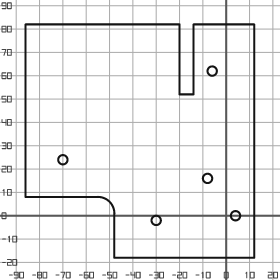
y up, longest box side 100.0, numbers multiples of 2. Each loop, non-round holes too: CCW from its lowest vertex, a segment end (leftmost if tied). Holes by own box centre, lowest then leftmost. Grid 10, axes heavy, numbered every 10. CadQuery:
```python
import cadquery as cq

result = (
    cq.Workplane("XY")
    .moveTo(-48.0, -18.0)
    .lineTo(12.0, -18.0)
    .lineTo(12.0, 82.0)
    .lineTo(-14.0, 82.0)
    .lineTo(-14.0, 52.0)
    .lineTo(-20.0, 52.0)
    .lineTo(-20.0, 82.0)
    .lineTo(-86.0, 82.0)
    .lineTo(-86.0, 8.0)
    .lineTo(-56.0, 8.0)
    .threePointArc((-50.0, 6.0), (-48.0, 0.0))
    .close()
    .moveTo(-30.0, -2.0)
    .circle(2.0)
    .moveTo(4.0, 0.0)
    .circle(2.0)
    .moveTo(-8.0, 16.0)
    .circle(2.0)
    .moveTo(-70.0, 24.0)
    .circle(2.0)
    .moveTo(-6.0, 62.0)
    .circle(2.0)
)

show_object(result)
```